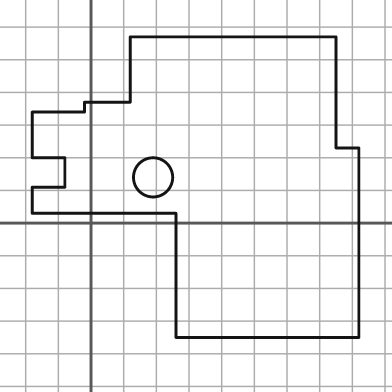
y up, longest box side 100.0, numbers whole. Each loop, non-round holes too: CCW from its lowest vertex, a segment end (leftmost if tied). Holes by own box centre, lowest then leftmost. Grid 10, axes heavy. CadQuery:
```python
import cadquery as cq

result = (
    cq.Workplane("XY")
    .moveTo(26.0, -35.0)
    .lineTo(82.0, -35.0)
    .lineTo(82.0, 23.0)
    .lineTo(75.0, 23.0)
    .lineTo(75.0, 57.0)
    .lineTo(12.0, 57.0)
    .lineTo(12.0, 37.0)
    .lineTo(-2.0, 37.0)
    .lineTo(-2.0, 34.0)
    .lineTo(-18.0, 34.0)
    .lineTo(-18.0, 20.0)
    .lineTo(-8.0, 20.0)
    .lineTo(-8.0, 11.0)
    .lineTo(-18.0, 11.0)
    .lineTo(-18.0, 3.0)
    .lineTo(26.0, 3.0)
    .close()
    .moveTo(19.0, 14.0)
    .circle(6.0)
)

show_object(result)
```